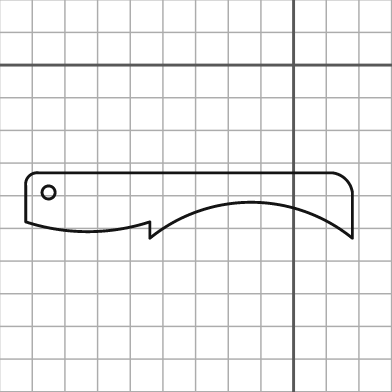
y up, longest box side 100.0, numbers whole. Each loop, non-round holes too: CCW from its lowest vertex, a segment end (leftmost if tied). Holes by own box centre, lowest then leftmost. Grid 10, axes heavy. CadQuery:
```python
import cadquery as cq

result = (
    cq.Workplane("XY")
    .moveTo(-44.0, -53.0)
    .threePointArc((-13.0, -42.0), (18.0, -53.0))
    .lineTo(18.0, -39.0)
    .threePointArc((16.0, -35.0), (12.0, -33.0))
    .lineTo(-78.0, -33.0)
    .threePointArc((-81.0, -34.0), (-82.0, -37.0))
    .lineTo(-82.0, -48.0)
    .threePointArc((-63.0, -51.0), (-44.0, -48.0))
    .close()
    .moveTo(-75.0, -39.0)
    .circle(2.0)
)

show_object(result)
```